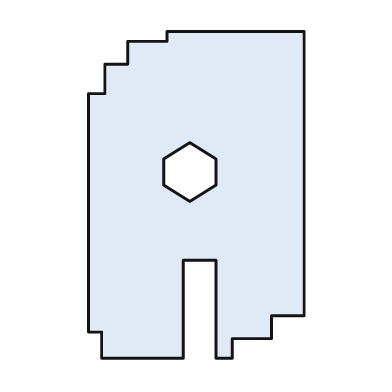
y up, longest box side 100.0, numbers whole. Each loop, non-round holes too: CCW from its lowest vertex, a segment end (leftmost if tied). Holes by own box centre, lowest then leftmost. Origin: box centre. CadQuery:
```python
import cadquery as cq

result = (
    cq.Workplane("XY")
    .moveTo(-29.0, -50.0)
    .lineTo(-4.0, -50.0)
    .lineTo(-4.0, -20.0)
    .lineTo(6.0, -20.0)
    .lineTo(6.0, -50.0)
    .lineTo(11.0, -50.0)
    .lineTo(11.0, -44.0)
    .lineTo(23.0, -44.0)
    .lineTo(23.0, -37.0)
    .lineTo(33.0, -37.0)
    .lineTo(33.0, 50.0)
    .lineTo(-9.0, 50.0)
    .lineTo(-9.0, 47.0)
    .lineTo(-21.0, 47.0)
    .lineTo(-21.0, 40.0)
    .lineTo(-28.0, 40.0)
    .lineTo(-28.0, 31.0)
    .lineTo(-33.0, 31.0)
    .lineTo(-33.0, -42.0)
    .lineTo(-29.0, -42.0)
    .close()
    .moveTo(-2.0, -2.0)
    .lineTo(6.0, 3.0)
    .lineTo(6.0, 11.0)
    .lineTo(-2.0, 16.0)
    .lineTo(-10.0, 11.0)
    .lineTo(-10.0, 3.0)
    .close()
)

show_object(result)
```